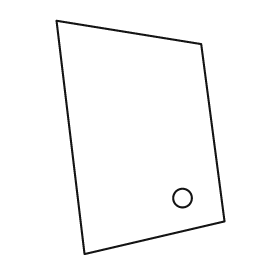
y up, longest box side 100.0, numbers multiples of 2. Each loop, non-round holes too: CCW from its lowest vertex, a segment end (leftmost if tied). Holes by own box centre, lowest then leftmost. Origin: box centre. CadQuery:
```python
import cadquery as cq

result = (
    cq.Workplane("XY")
    .moveTo(-24.0, -50.0)
    .lineTo(36.0, -36.0)
    .lineTo(26.0, 40.0)
    .lineTo(-36.0, 50.0)
    .close()
    .moveTo(18.0, -26.0)
    .circle(4.0)
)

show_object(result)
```